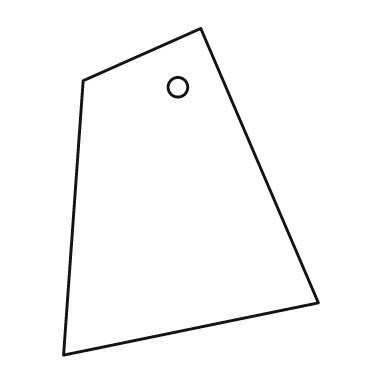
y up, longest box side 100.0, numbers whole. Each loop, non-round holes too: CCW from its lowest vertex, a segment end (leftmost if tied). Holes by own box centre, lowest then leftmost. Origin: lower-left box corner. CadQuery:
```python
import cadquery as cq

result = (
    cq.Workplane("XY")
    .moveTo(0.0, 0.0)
    .lineTo(78.0, 16.0)
    .lineTo(42.0, 100.0)
    .lineTo(6.0, 84.0)
    .close()
    .moveTo(35.0, 82.0)
    .circle(3.0)
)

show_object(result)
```